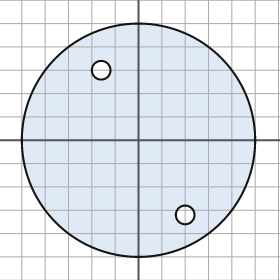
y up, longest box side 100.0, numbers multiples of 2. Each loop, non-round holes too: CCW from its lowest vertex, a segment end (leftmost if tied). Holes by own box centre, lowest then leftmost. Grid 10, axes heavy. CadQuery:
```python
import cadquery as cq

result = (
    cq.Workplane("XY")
    .moveTo(0.0, 0.0)
    .circle(50.0)
    .moveTo(20.0, -32.0)
    .circle(4.0)
    .moveTo(-16.0, 30.0)
    .circle(4.0)
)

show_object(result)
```